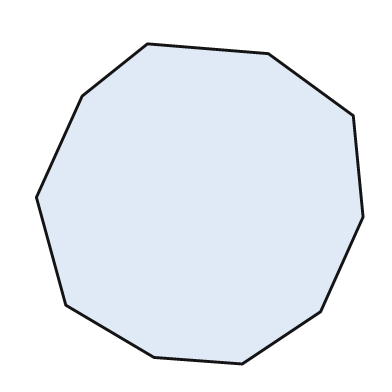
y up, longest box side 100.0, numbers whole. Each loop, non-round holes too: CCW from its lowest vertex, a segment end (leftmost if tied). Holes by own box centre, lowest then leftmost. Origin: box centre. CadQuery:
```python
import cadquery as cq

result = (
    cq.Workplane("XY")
    .moveTo(13.0, -49.0)
    .lineTo(37.0, -33.0)
    .lineTo(50.0, -4.0)
    .lineTo(47.0, 27.0)
    .lineTo(21.0, 46.0)
    .lineTo(-16.0, 49.0)
    .lineTo(-36.0, 33.0)
    .lineTo(-50.0, 2.0)
    .lineTo(-41.0, -31.0)
    .lineTo(-14.0, -47.0)
    .close()
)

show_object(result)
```